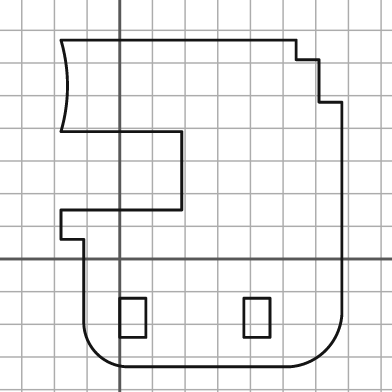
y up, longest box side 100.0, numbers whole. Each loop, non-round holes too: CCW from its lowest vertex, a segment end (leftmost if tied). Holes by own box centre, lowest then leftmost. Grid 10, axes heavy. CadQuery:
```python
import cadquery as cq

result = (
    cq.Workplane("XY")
    .moveTo(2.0, -33.0)
    .lineTo(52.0, -33.0)
    .threePointArc((63.0, -28.0), (68.0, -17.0))
    .lineTo(68.0, 48.0)
    .lineTo(61.0, 48.0)
    .lineTo(61.0, 61.0)
    .lineTo(54.0, 61.0)
    .lineTo(54.0, 67.0)
    .lineTo(-18.0, 67.0)
    .threePointArc((-16.0, 53.0), (-18.0, 39.0))
    .lineTo(19.0, 39.0)
    .lineTo(19.0, 15.0)
    .lineTo(-18.0, 15.0)
    .lineTo(-18.0, 6.0)
    .lineTo(-11.0, 6.0)
    .lineTo(-11.0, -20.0)
    .threePointArc((-7.0, -29.0), (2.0, -33.0))
    .close()
    .moveTo(0.0, -24.0)
    .lineTo(8.0, -24.0)
    .lineTo(8.0, -12.0)
    .lineTo(0.0, -12.0)
    .close()
    .moveTo(38.0, -24.0)
    .lineTo(46.0, -24.0)
    .lineTo(46.0, -12.0)
    .lineTo(38.0, -12.0)
    .close()
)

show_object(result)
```